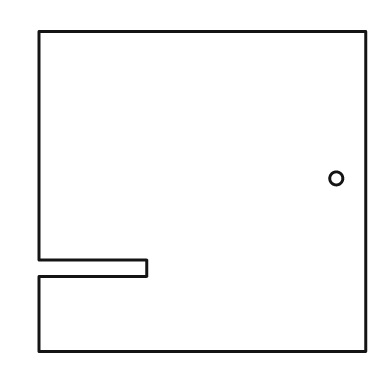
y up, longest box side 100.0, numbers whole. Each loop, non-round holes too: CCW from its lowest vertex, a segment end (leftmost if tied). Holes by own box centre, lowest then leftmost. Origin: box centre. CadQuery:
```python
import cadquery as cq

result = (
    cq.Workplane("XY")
    .moveTo(-50.0, -49.0)
    .lineTo(50.0, -49.0)
    .lineTo(50.0, 49.0)
    .lineTo(-50.0, 49.0)
    .lineTo(-50.0, -21.0)
    .lineTo(-17.0, -21.0)
    .lineTo(-17.0, -26.0)
    .lineTo(-50.0, -26.0)
    .close()
    .moveTo(41.0, 4.0)
    .circle(2.0)
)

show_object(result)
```